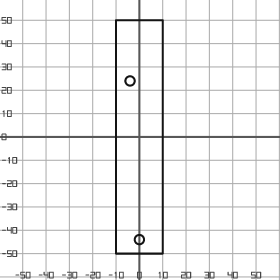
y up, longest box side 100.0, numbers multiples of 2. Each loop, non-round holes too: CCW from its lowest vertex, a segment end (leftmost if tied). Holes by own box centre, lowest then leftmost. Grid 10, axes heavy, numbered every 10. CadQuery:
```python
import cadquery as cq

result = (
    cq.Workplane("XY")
    .moveTo(-10.0, -50.0)
    .lineTo(10.0, -50.0)
    .lineTo(10.0, 50.0)
    .lineTo(-10.0, 50.0)
    .close()
    .moveTo(0.0, -44.0)
    .circle(2.0)
    .moveTo(-4.0, 24.0)
    .circle(2.0)
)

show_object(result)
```